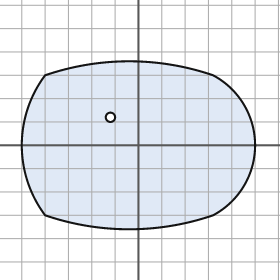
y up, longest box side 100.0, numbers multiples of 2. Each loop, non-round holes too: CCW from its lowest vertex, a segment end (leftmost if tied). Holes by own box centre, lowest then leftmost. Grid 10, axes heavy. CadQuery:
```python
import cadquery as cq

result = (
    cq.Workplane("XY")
    .moveTo(-40.0, -30.0)
    .threePointArc((-4.0, -36.0), (32.0, -30.0))
    .threePointArc((50.0, 0.0), (32.0, 30.0))
    .threePointArc((-4.0, 36.0), (-40.0, 30.0))
    .threePointArc((-50.0, 0.0), (-40.0, -30.0))
    .close()
    .moveTo(-12.0, 12.0)
    .circle(2.0)
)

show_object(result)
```